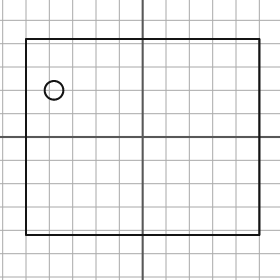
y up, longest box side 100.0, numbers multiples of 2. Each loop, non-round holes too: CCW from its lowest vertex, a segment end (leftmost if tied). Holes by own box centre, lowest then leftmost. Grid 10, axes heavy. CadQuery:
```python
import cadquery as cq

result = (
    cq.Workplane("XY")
    .moveTo(-50.0, -42.0)
    .lineTo(50.0, -42.0)
    .lineTo(50.0, 42.0)
    .lineTo(-50.0, 42.0)
    .close()
    .moveTo(-38.0, 20.0)
    .circle(4.0)
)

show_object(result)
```